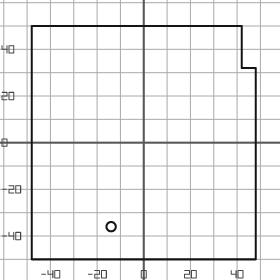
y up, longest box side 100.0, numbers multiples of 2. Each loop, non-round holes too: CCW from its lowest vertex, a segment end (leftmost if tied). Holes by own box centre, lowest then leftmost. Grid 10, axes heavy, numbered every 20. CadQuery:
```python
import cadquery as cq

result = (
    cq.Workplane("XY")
    .moveTo(-48.0, -50.0)
    .lineTo(48.0, -50.0)
    .lineTo(48.0, 32.0)
    .lineTo(42.0, 32.0)
    .lineTo(42.0, 50.0)
    .lineTo(-48.0, 50.0)
    .close()
    .moveTo(-14.0, -36.0)
    .circle(2.0)
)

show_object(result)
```